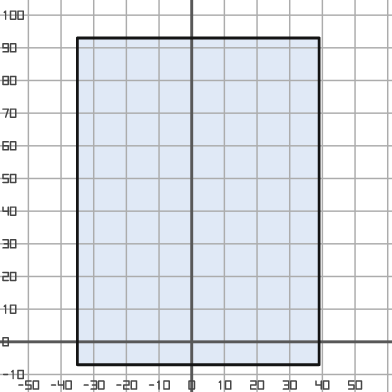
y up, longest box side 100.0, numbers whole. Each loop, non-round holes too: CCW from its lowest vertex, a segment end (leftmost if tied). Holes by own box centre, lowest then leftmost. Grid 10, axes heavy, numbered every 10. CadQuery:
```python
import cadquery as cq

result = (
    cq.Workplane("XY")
    .moveTo(-35.0, -7.0)
    .lineTo(39.0, -7.0)
    .lineTo(39.0, 93.0)
    .lineTo(-35.0, 93.0)
    .close()
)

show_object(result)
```